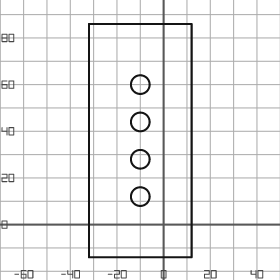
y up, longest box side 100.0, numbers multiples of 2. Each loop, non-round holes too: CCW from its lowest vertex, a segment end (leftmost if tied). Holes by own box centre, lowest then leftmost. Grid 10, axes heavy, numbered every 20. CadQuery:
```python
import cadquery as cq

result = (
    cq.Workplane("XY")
    .moveTo(-32.0, -14.0)
    .lineTo(12.0, -14.0)
    .lineTo(12.0, 86.0)
    .lineTo(-32.0, 86.0)
    .close()
    .moveTo(-10.0, 12.0)
    .circle(4.0)
    .moveTo(-10.0, 28.0)
    .circle(4.0)
    .moveTo(-10.0, 44.0)
    .circle(4.0)
    .moveTo(-10.0, 60.0)
    .circle(4.0)
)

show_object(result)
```